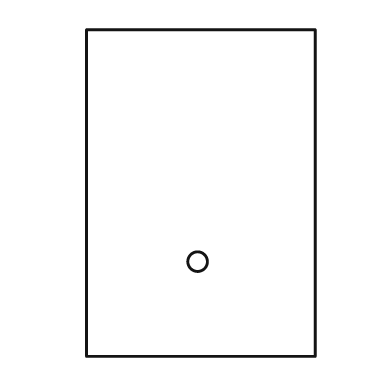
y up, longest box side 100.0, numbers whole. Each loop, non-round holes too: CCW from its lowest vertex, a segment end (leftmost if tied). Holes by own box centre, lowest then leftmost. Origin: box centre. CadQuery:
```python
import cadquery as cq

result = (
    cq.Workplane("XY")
    .moveTo(-35.0, -50.0)
    .lineTo(35.0, -50.0)
    .lineTo(35.0, 50.0)
    .lineTo(-35.0, 50.0)
    .close()
    .moveTo(-1.0, -21.0)
    .circle(3.0)
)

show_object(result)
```